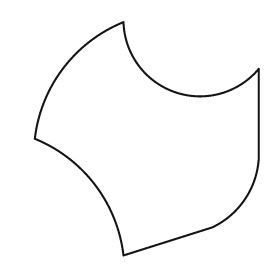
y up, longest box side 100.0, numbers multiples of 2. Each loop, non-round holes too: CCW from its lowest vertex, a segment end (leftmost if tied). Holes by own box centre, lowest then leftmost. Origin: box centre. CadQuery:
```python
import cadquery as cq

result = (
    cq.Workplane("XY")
    .moveTo(-10.0, -50.0)
    .lineTo(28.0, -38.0)
    .threePointArc((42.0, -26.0), (48.0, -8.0))
    .lineTo(48.0, 30.0)
    .threePointArc((12.0, 20.0), (-10.0, 50.0))
    .threePointArc((-36.0, 30.0), (-48.0, 0.0))
    .threePointArc((-22.0, -20.0), (-10.0, -50.0))
    .close()
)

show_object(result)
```